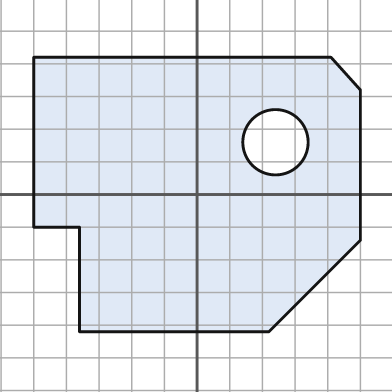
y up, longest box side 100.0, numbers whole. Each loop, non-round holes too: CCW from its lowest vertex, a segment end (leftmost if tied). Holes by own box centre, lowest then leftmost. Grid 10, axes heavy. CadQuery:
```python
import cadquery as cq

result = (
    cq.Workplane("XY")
    .moveTo(-36.0, -42.0)
    .lineTo(22.0, -42.0)
    .lineTo(50.0, -14.0)
    .lineTo(50.0, 32.0)
    .lineTo(41.0, 42.0)
    .lineTo(-50.0, 42.0)
    .lineTo(-50.0, -10.0)
    .lineTo(-36.0, -10.0)
    .close()
    .moveTo(24.0, 16.0)
    .circle(10.0)
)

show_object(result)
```